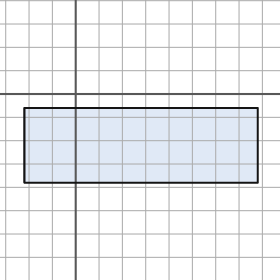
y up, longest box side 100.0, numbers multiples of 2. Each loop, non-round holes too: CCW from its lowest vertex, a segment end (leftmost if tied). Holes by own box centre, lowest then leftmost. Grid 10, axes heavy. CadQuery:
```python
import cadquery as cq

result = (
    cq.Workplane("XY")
    .moveTo(-22.0, -38.0)
    .lineTo(78.0, -38.0)
    .lineTo(78.0, -6.0)
    .lineTo(-22.0, -6.0)
    .close()
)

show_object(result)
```